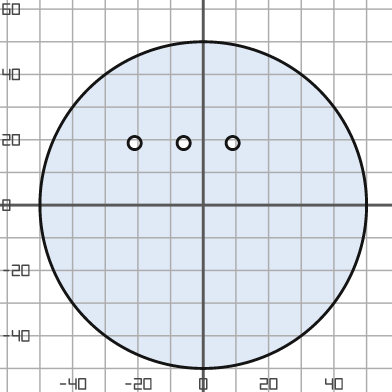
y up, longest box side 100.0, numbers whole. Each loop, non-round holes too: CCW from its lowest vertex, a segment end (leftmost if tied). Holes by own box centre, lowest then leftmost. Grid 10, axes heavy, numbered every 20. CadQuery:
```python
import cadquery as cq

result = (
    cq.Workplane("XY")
    .moveTo(0.0, 0.0)
    .circle(50.0)
    .moveTo(-21.0, 19.0)
    .circle(2.0)
    .moveTo(-6.0, 19.0)
    .circle(2.0)
    .moveTo(9.0, 19.0)
    .circle(2.0)
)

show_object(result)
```